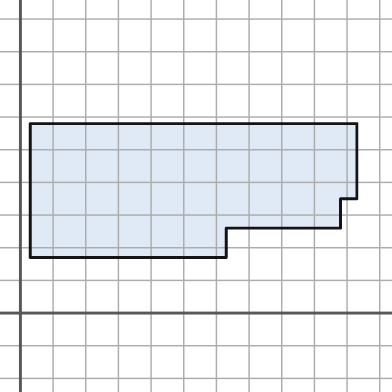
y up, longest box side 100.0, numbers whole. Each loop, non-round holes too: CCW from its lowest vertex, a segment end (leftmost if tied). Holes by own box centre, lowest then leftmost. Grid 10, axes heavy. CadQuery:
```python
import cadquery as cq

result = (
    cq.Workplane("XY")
    .moveTo(3.0, 17.0)
    .lineTo(63.0, 17.0)
    .lineTo(63.0, 26.0)
    .lineTo(98.0, 26.0)
    .lineTo(98.0, 35.0)
    .lineTo(103.0, 35.0)
    .lineTo(103.0, 58.0)
    .lineTo(3.0, 58.0)
    .close()
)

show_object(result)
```